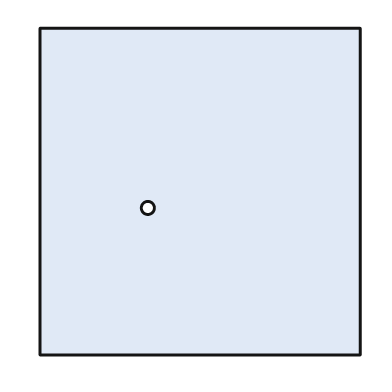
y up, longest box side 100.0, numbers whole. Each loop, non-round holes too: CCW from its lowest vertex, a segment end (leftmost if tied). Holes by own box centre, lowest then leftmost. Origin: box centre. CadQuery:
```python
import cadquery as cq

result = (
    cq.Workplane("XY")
    .moveTo(-49.0, -50.0)
    .lineTo(49.0, -50.0)
    .lineTo(49.0, 50.0)
    .lineTo(-49.0, 50.0)
    .close()
    .moveTo(-16.0, -5.0)
    .circle(2.0)
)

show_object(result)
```